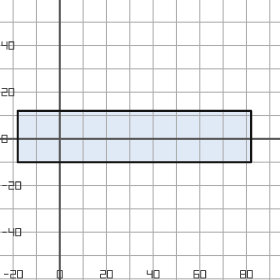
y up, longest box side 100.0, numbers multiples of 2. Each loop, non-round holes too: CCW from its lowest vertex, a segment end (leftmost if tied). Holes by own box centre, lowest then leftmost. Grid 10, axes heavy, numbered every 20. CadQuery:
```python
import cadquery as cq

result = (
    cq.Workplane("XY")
    .moveTo(-18.0, -10.0)
    .lineTo(82.0, -10.0)
    .lineTo(82.0, 12.0)
    .lineTo(-18.0, 12.0)
    .close()
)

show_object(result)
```